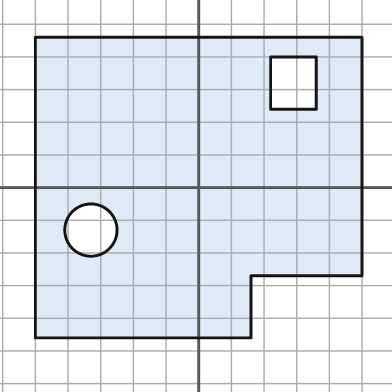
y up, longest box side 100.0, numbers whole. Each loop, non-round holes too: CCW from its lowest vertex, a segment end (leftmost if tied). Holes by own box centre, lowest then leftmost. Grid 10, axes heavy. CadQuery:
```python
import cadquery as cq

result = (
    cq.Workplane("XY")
    .moveTo(-50.0, -46.0)
    .lineTo(16.0, -46.0)
    .lineTo(16.0, -27.0)
    .lineTo(50.0, -27.0)
    .lineTo(50.0, 46.0)
    .lineTo(-50.0, 46.0)
    .close()
    .moveTo(-33.0, -13.0)
    .circle(8.0)
    .moveTo(22.0, 24.0)
    .lineTo(36.0, 24.0)
    .lineTo(36.0, 40.0)
    .lineTo(22.0, 40.0)
    .close()
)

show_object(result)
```